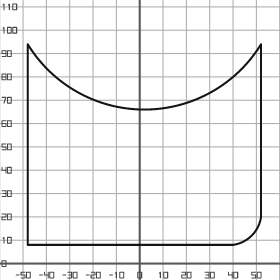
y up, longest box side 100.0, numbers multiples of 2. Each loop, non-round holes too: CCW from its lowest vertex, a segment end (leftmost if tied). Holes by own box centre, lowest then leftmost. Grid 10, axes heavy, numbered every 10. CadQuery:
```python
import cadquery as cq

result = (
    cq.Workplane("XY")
    .moveTo(-48.0, 8.0)
    .lineTo(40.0, 8.0)
    .threePointArc((48.0, 12.0), (52.0, 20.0))
    .lineTo(52.0, 94.0)
    .threePointArc((2.0, 66.0), (-48.0, 94.0))
    .close()
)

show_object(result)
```